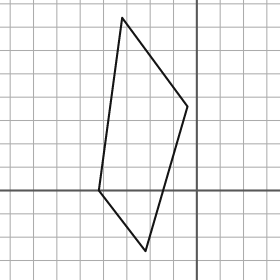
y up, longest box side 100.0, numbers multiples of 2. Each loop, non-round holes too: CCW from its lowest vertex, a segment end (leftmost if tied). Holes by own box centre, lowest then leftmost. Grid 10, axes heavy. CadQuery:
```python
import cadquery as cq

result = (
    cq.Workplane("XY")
    .moveTo(-22.0, -26.0)
    .lineTo(-4.0, 36.0)
    .lineTo(-32.0, 74.0)
    .lineTo(-42.0, 0.0)
    .close()
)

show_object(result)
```